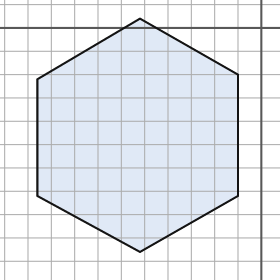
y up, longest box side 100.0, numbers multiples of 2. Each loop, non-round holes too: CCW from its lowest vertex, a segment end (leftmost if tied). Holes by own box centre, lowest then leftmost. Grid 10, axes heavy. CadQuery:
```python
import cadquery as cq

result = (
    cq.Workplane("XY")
    .moveTo(-52.0, -96.0)
    .lineTo(-10.0, -72.0)
    .lineTo(-10.0, -20.0)
    .lineTo(-52.0, 4.0)
    .lineTo(-96.0, -22.0)
    .lineTo(-96.0, -72.0)
    .close()
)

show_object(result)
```